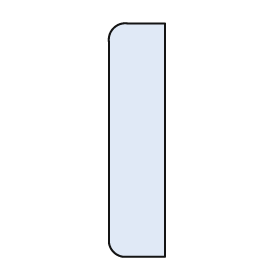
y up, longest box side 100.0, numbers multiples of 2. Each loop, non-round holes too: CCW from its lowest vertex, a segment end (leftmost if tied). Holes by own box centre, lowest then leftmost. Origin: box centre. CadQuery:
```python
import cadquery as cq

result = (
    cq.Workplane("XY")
    .moveTo(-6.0, -50.0)
    .lineTo(12.0, -50.0)
    .lineTo(12.0, 50.0)
    .lineTo(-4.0, 50.0)
    .threePointArc((-10.0, 48.0), (-12.0, 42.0))
    .lineTo(-12.0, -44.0)
    .threePointArc((-10.0, -48.0), (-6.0, -50.0))
    .close()
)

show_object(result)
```